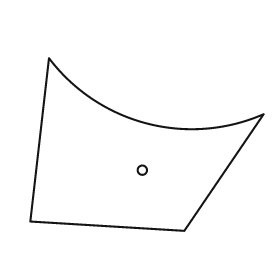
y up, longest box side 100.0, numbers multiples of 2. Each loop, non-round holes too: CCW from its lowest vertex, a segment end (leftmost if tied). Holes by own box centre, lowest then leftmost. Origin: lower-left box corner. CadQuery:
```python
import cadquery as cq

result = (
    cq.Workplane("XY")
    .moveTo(66.0, 0.0)
    .lineTo(100.0, 50.0)
    .threePointArc((50.0, 46.0), (8.0, 74.0))
    .lineTo(0.0, 4.0)
    .close()
    .moveTo(48.0, 26.0)
    .circle(2.0)
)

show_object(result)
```